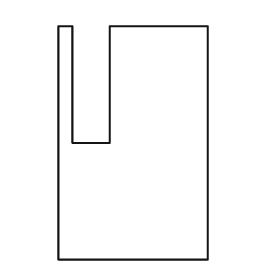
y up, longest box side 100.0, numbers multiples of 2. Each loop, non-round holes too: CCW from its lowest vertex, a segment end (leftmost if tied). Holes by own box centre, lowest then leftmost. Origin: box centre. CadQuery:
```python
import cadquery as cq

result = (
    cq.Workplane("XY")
    .moveTo(-32.0, -50.0)
    .lineTo(32.0, -50.0)
    .lineTo(32.0, 50.0)
    .lineTo(-10.0, 50.0)
    .lineTo(-10.0, 0.0)
    .lineTo(-26.0, 0.0)
    .lineTo(-26.0, 50.0)
    .lineTo(-32.0, 50.0)
    .close()
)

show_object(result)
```